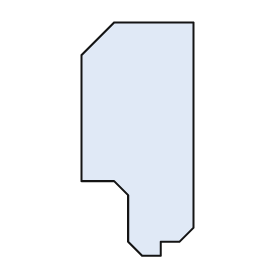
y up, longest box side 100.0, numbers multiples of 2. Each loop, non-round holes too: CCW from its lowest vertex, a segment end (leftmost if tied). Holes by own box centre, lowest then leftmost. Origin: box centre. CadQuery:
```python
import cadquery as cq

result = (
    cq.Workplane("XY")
    .moveTo(2.0, -50.0)
    .lineTo(10.0, -50.0)
    .lineTo(10.0, -44.0)
    .lineTo(18.0, -44.0)
    .lineTo(24.0, -38.0)
    .lineTo(24.0, 50.0)
    .lineTo(-10.0, 50.0)
    .lineTo(-24.0, 36.0)
    .lineTo(-24.0, -18.0)
    .lineTo(-10.0, -18.0)
    .lineTo(-4.0, -24.0)
    .lineTo(-4.0, -44.0)
    .close()
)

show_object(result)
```